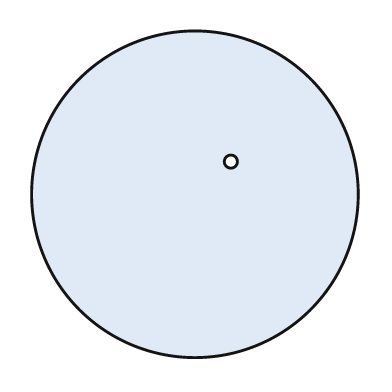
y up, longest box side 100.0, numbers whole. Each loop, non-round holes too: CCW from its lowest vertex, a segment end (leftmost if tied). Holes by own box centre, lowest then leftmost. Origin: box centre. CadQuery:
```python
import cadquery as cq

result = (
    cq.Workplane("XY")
    .moveTo(0.0, 0.0)
    .circle(50.0)
    .moveTo(11.0, 10.0)
    .circle(2.0)
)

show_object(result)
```